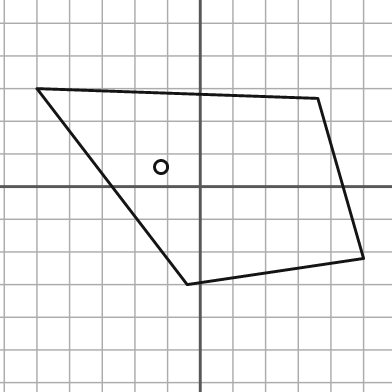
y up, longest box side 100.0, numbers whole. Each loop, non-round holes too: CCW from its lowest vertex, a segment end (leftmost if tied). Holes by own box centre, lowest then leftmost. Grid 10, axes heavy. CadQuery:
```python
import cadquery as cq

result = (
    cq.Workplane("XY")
    .moveTo(-4.0, -30.0)
    .lineTo(50.0, -22.0)
    .lineTo(36.0, 27.0)
    .lineTo(-50.0, 30.0)
    .close()
    .moveTo(-12.0, 6.0)
    .circle(2.0)
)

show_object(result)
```